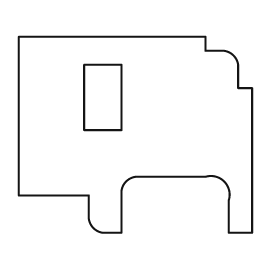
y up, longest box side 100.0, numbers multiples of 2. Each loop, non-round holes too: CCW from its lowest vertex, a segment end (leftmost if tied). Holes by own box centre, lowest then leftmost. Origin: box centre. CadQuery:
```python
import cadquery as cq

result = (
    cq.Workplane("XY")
    .moveTo(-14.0, -42.0)
    .lineTo(-6.0, -42.0)
    .lineTo(-6.0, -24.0)
    .threePointArc((-4.0, -20.0), (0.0, -18.0))
    .lineTo(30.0, -18.0)
    .threePointArc((38.0, -20.0), (40.0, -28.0))
    .lineTo(40.0, -42.0)
    .lineTo(50.0, -42.0)
    .lineTo(50.0, 20.0)
    .lineTo(44.0, 20.0)
    .lineTo(44.0, 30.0)
    .threePointArc((42.0, 34.0), (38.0, 36.0))
    .lineTo(30.0, 36.0)
    .lineTo(30.0, 42.0)
    .lineTo(-50.0, 42.0)
    .lineTo(-50.0, -26.0)
    .lineTo(-20.0, -26.0)
    .lineTo(-20.0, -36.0)
    .threePointArc((-18.0, -40.0), (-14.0, -42.0))
    .close()
    .moveTo(-22.0, 2.0)
    .lineTo(-6.0, 2.0)
    .lineTo(-6.0, 30.0)
    .lineTo(-22.0, 30.0)
    .close()
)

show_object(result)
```